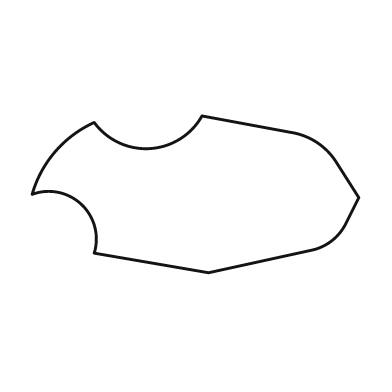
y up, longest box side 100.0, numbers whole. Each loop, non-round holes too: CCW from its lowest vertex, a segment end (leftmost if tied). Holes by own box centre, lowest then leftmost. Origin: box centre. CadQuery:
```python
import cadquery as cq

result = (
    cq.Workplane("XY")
    .moveTo(4.0, -24.0)
    .lineTo(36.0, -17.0)
    .threePointArc((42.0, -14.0), (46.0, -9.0))
    .lineTo(50.0, -1.0)
    .lineTo(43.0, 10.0)
    .threePointArc((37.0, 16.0), (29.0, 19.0))
    .lineTo(2.0, 24.0)
    .threePointArc((-14.0, 14.0), (-31.0, 22.0))
    .threePointArc((-43.0, 13.0), (-50.0, 0.0))
    .threePointArc((-35.0, -3.0), (-31.0, -18.0))
    .close()
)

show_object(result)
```